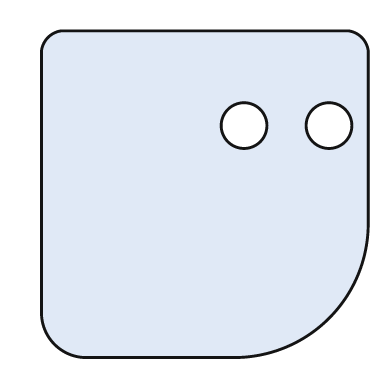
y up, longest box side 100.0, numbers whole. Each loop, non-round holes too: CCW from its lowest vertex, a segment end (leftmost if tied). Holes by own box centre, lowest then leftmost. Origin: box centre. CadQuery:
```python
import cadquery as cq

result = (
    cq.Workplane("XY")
    .moveTo(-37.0, -50.0)
    .lineTo(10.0, -50.0)
    .threePointArc((38.0, -38.0), (50.0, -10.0))
    .lineTo(50.0, 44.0)
    .threePointArc((48.0, 48.0), (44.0, 50.0))
    .lineTo(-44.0, 50.0)
    .threePointArc((-48.0, 48.0), (-50.0, 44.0))
    .lineTo(-50.0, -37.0)
    .threePointArc((-46.0, -46.0), (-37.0, -50.0))
    .close()
    .moveTo(12.0, 21.0)
    .circle(7.0)
    .moveTo(38.0, 21.0)
    .circle(7.0)
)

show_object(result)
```